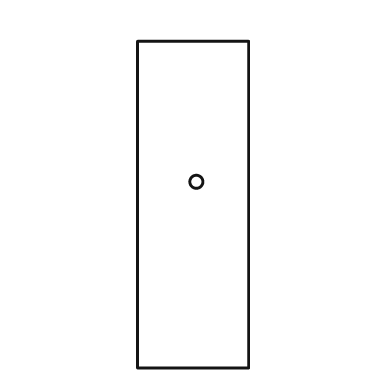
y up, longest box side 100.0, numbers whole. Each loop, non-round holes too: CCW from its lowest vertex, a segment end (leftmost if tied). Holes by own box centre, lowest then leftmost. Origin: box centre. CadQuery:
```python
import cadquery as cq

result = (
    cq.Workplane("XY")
    .moveTo(-17.0, -50.0)
    .lineTo(17.0, -50.0)
    .lineTo(17.0, 50.0)
    .lineTo(-17.0, 50.0)
    .close()
    .moveTo(1.0, 7.0)
    .circle(2.0)
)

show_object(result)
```